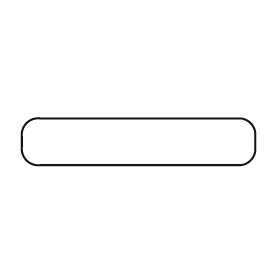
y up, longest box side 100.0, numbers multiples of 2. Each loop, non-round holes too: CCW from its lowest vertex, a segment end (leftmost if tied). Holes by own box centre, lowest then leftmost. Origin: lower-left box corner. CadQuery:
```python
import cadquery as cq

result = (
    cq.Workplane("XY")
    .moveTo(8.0, 0.0)
    .lineTo(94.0, 0.0)
    .threePointArc((98.0, 2.0), (100.0, 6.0))
    .lineTo(100.0, 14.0)
    .threePointArc((98.0, 18.0), (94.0, 20.0))
    .lineTo(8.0, 20.0)
    .threePointArc((2.0, 18.0), (0.0, 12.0))
    .lineTo(0.0, 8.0)
    .threePointArc((2.0, 2.0), (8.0, 0.0))
    .close()
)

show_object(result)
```